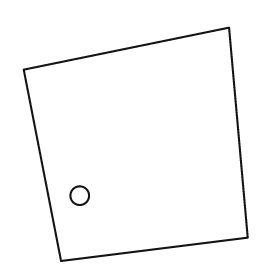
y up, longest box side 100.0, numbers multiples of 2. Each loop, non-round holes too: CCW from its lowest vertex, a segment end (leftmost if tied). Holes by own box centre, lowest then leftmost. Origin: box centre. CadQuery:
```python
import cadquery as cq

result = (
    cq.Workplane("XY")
    .moveTo(-32.0, -50.0)
    .lineTo(48.0, -40.0)
    .lineTo(40.0, 50.0)
    .lineTo(-48.0, 32.0)
    .close()
    .moveTo(-24.0, -22.0)
    .circle(4.0)
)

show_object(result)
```